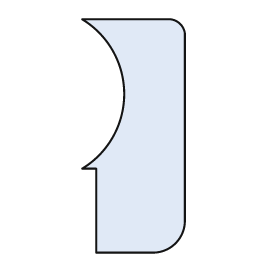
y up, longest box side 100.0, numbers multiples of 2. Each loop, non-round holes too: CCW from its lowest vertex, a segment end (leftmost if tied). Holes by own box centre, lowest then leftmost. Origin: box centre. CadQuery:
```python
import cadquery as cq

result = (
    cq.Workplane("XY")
    .moveTo(-16.0, -50.0)
    .lineTo(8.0, -50.0)
    .threePointArc((18.0, -46.0), (22.0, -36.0))
    .lineTo(22.0, 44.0)
    .threePointArc((20.0, 48.0), (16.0, 50.0))
    .lineTo(-22.0, 50.0)
    .threePointArc((-4.0, 18.0), (-22.0, -14.0))
    .lineTo(-16.0, -14.0)
    .close()
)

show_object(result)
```